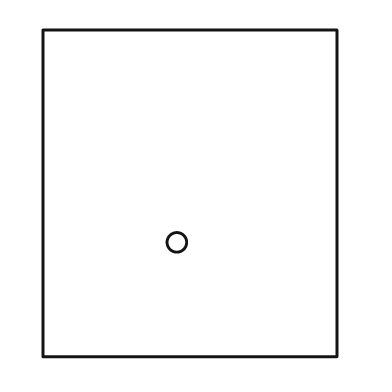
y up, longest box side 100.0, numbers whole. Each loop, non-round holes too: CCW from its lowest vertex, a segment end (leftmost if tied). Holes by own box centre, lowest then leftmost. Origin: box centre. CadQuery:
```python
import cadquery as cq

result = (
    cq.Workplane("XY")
    .moveTo(-45.0, -50.0)
    .lineTo(45.0, -50.0)
    .lineTo(45.0, 50.0)
    .lineTo(-45.0, 50.0)
    .close()
    .moveTo(-4.0, -15.0)
    .circle(3.0)
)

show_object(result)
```